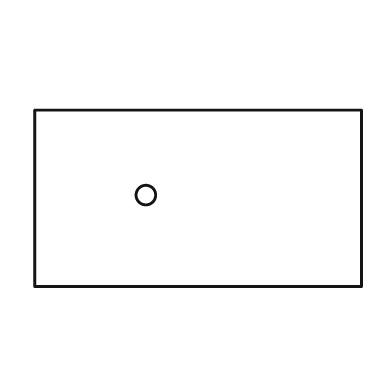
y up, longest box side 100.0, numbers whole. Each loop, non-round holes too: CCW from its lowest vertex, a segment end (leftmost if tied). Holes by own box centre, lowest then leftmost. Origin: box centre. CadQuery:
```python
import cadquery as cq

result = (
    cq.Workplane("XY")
    .moveTo(-50.0, -27.0)
    .lineTo(50.0, -27.0)
    .lineTo(50.0, 27.0)
    .lineTo(-50.0, 27.0)
    .close()
    .moveTo(-16.0, 1.0)
    .circle(3.0)
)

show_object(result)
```